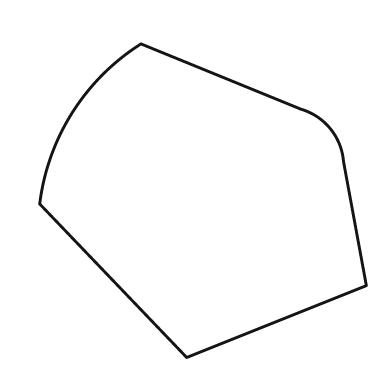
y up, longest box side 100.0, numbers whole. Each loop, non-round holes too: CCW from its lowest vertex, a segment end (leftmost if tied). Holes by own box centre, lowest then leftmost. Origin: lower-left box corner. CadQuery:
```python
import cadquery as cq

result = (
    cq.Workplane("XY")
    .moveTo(45.0, 0.0)
    .lineTo(100.0, 22.0)
    .lineTo(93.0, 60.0)
    .threePointArc((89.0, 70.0), (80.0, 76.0))
    .lineTo(31.0, 96.0)
    .threePointArc((10.0, 75.0), (0.0, 47.0))
    .close()
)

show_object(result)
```